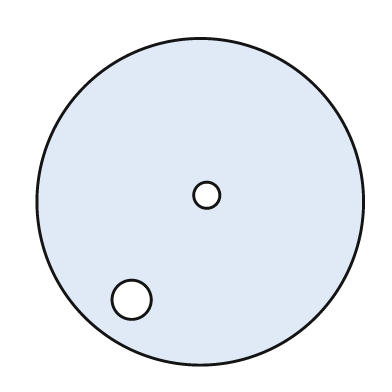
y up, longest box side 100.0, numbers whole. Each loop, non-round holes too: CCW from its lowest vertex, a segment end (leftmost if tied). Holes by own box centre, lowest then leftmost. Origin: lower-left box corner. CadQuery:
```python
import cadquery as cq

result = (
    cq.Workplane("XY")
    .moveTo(50.0, 50.0)
    .circle(50.0)
    .moveTo(29.0, 20.0)
    .circle(6.0)
    .moveTo(52.0, 52.0)
    .circle(4.0)
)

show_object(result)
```